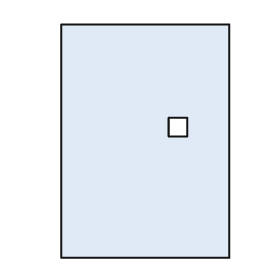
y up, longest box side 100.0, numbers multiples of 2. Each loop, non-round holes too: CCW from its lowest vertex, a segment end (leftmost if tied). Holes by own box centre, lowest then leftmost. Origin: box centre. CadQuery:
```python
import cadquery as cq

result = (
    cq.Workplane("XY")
    .moveTo(-36.0, -50.0)
    .lineTo(36.0, -50.0)
    .lineTo(36.0, 50.0)
    .lineTo(-36.0, 50.0)
    .close()
    .moveTo(10.0, 2.0)
    .lineTo(18.0, 2.0)
    .lineTo(18.0, 10.0)
    .lineTo(10.0, 10.0)
    .close()
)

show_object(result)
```